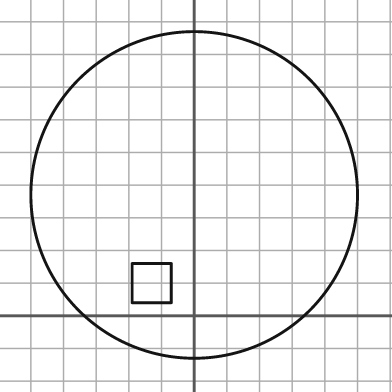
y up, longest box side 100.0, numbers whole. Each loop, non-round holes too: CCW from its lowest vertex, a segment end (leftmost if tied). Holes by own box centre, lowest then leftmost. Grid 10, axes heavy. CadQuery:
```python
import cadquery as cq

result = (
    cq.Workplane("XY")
    .moveTo(0.0, 37.0)
    .circle(50.0)
    .moveTo(-19.0, 4.0)
    .lineTo(-7.0, 4.0)
    .lineTo(-7.0, 16.0)
    .lineTo(-19.0, 16.0)
    .close()
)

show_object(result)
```